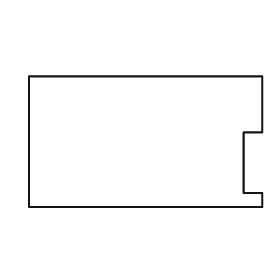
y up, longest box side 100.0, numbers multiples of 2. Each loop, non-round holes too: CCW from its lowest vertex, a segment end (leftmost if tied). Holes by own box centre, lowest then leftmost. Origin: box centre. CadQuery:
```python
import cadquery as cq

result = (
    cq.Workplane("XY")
    .moveTo(-50.0, -28.0)
    .lineTo(50.0, -28.0)
    .lineTo(50.0, -22.0)
    .lineTo(42.0, -22.0)
    .lineTo(42.0, 4.0)
    .lineTo(50.0, 4.0)
    .lineTo(50.0, 28.0)
    .lineTo(-50.0, 28.0)
    .close()
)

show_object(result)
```